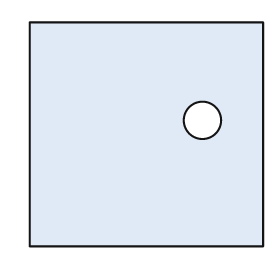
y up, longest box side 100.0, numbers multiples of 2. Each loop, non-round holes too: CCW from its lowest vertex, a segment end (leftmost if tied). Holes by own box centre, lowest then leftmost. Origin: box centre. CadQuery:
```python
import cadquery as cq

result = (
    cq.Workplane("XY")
    .moveTo(-50.0, -48.0)
    .lineTo(50.0, -48.0)
    .lineTo(50.0, 48.0)
    .lineTo(-50.0, 48.0)
    .close()
    .moveTo(24.0, 6.0)
    .circle(8.0)
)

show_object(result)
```